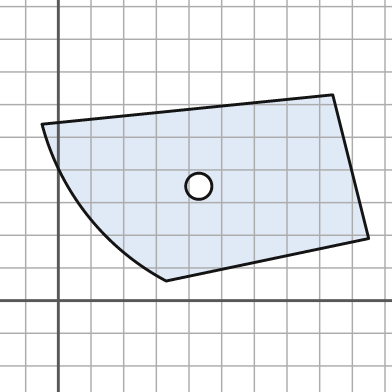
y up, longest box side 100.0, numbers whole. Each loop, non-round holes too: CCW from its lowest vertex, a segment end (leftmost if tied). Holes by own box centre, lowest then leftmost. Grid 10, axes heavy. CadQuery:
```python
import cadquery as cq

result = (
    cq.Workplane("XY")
    .moveTo(33.0, 6.0)
    .lineTo(95.0, 19.0)
    .lineTo(84.0, 63.0)
    .lineTo(-5.0, 54.0)
    .threePointArc((9.0, 26.0), (33.0, 6.0))
    .close()
    .moveTo(43.0, 35.0)
    .circle(4.0)
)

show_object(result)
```